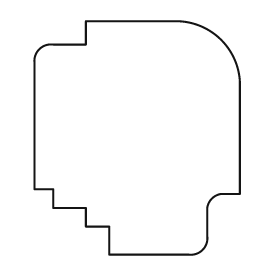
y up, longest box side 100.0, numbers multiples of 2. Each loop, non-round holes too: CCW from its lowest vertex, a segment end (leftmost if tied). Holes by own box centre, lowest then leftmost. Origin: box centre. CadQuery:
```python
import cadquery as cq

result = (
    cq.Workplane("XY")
    .moveTo(-12.0, -50.0)
    .lineTo(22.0, -50.0)
    .threePointArc((28.0, -48.0), (30.0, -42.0))
    .lineTo(30.0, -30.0)
    .threePointArc((32.0, -26.0), (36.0, -24.0))
    .lineTo(44.0, -24.0)
    .lineTo(44.0, 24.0)
    .threePointArc((36.0, 42.0), (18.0, 50.0))
    .lineTo(-22.0, 50.0)
    .lineTo(-22.0, 40.0)
    .lineTo(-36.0, 40.0)
    .threePointArc((-42.0, 38.0), (-44.0, 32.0))
    .lineTo(-44.0, -22.0)
    .lineTo(-36.0, -22.0)
    .lineTo(-36.0, -30.0)
    .lineTo(-22.0, -30.0)
    .lineTo(-22.0, -38.0)
    .lineTo(-12.0, -38.0)
    .close()
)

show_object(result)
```